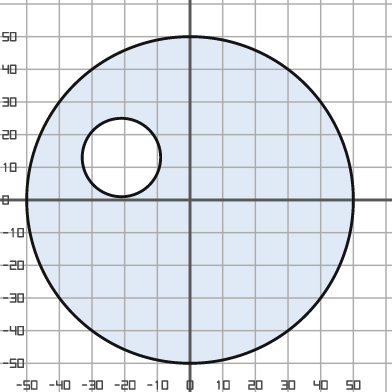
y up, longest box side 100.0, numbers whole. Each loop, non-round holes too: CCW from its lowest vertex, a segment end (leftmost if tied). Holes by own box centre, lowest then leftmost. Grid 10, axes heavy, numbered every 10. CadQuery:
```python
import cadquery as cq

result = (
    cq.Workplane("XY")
    .moveTo(0.0, 0.0)
    .circle(50.0)
    .moveTo(-21.0, 13.0)
    .circle(12.0)
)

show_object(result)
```